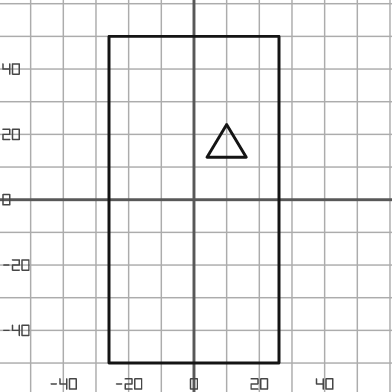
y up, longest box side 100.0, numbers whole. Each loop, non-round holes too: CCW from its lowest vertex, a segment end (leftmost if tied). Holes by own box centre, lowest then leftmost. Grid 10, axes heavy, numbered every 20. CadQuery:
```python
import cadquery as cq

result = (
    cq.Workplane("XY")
    .moveTo(-26.0, -50.0)
    .lineTo(26.0, -50.0)
    .lineTo(26.0, 50.0)
    .lineTo(-26.0, 50.0)
    .close()
    .moveTo(4.0, 13.0)
    .lineTo(16.0, 13.0)
    .lineTo(10.0, 23.0)
    .close()
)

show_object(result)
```